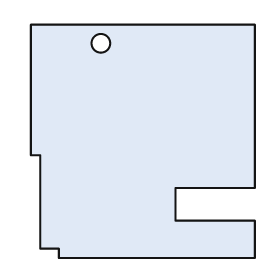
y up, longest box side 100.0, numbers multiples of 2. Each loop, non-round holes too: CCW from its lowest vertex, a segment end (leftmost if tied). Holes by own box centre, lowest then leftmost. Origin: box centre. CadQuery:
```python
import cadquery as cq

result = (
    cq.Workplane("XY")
    .moveTo(-36.0, -50.0)
    .lineTo(48.0, -50.0)
    .lineTo(48.0, -34.0)
    .lineTo(14.0, -34.0)
    .lineTo(14.0, -20.0)
    .lineTo(48.0, -20.0)
    .lineTo(48.0, 50.0)
    .lineTo(-48.0, 50.0)
    .lineTo(-48.0, -6.0)
    .lineTo(-44.0, -6.0)
    .lineTo(-44.0, -46.0)
    .lineTo(-36.0, -46.0)
    .close()
    .moveTo(-18.0, 42.0)
    .circle(4.0)
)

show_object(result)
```